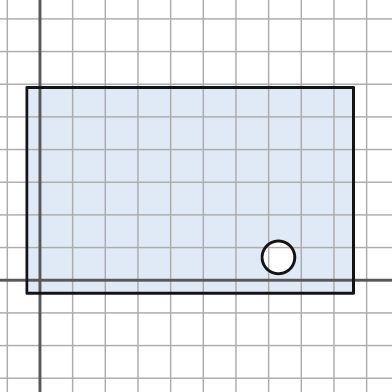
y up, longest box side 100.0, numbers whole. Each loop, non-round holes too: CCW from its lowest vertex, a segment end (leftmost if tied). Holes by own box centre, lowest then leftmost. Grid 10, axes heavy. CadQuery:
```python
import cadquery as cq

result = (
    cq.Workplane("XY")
    .moveTo(-4.0, -4.0)
    .lineTo(96.0, -4.0)
    .lineTo(96.0, 59.0)
    .lineTo(-4.0, 59.0)
    .close()
    .moveTo(73.0, 7.0)
    .circle(5.0)
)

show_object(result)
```